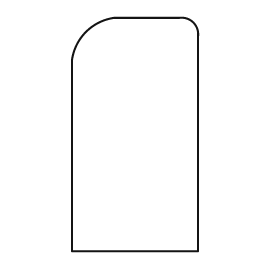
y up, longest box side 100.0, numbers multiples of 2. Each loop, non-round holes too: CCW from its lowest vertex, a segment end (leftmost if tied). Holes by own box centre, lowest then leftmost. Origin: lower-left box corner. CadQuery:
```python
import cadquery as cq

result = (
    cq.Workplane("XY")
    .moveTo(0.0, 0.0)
    .lineTo(54.0, 0.0)
    .lineTo(54.0, 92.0)
    .threePointArc((52.0, 98.0), (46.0, 100.0))
    .lineTo(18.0, 100.0)
    .threePointArc((6.0, 94.0), (0.0, 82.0))
    .close()
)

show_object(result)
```